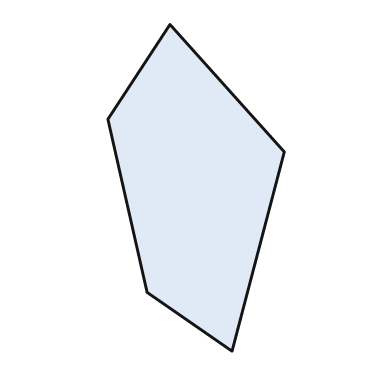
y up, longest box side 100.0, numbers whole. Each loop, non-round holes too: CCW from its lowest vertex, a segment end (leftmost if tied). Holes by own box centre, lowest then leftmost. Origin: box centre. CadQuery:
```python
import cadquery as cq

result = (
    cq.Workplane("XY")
    .moveTo(11.0, -50.0)
    .lineTo(27.0, 11.0)
    .lineTo(-8.0, 50.0)
    .lineTo(-27.0, 21.0)
    .lineTo(-15.0, -32.0)
    .close()
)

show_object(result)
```